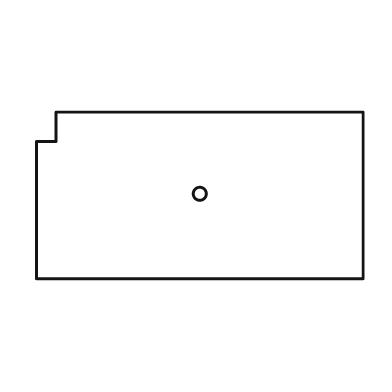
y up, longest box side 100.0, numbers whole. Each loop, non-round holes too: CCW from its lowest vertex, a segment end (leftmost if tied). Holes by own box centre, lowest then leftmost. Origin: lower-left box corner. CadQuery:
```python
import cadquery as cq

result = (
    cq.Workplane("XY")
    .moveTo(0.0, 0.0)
    .lineTo(100.0, 0.0)
    .lineTo(100.0, 51.0)
    .lineTo(6.0, 51.0)
    .lineTo(6.0, 42.0)
    .lineTo(0.0, 42.0)
    .close()
    .moveTo(50.0, 26.0)
    .circle(2.0)
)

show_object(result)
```